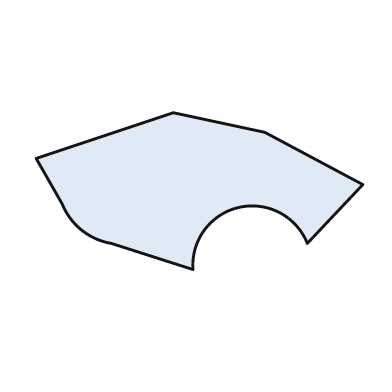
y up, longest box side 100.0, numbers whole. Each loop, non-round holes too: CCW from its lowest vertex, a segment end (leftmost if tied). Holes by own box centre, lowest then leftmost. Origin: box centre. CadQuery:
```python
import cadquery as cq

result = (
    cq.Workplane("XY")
    .moveTo(-2.0, -24.0)
    .threePointArc((12.0, -5.0), (33.0, -16.0))
    .lineTo(50.0, 2.0)
    .lineTo(20.0, 18.0)
    .lineTo(-8.0, 24.0)
    .lineTo(-50.0, 10.0)
    .lineTo(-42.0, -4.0)
    .threePointArc((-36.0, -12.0), (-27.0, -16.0))
    .close()
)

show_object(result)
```